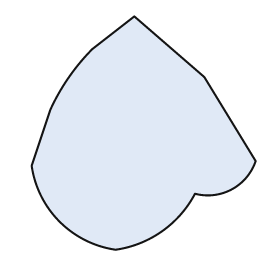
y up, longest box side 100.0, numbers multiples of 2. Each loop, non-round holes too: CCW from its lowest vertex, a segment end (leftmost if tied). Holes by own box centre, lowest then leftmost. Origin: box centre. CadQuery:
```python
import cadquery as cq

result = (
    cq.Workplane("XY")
    .moveTo(-12.0, -50.0)
    .threePointArc((8.0, -42.0), (22.0, -26.0))
    .threePointArc((38.0, -24.0), (48.0, -12.0))
    .lineTo(26.0, 24.0)
    .lineTo(-4.0, 50.0)
    .lineTo(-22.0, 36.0)
    .threePointArc((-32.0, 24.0), (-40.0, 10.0))
    .lineTo(-48.0, -14.0)
    .threePointArc((-36.0, -38.0), (-12.0, -50.0))
    .close()
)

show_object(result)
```